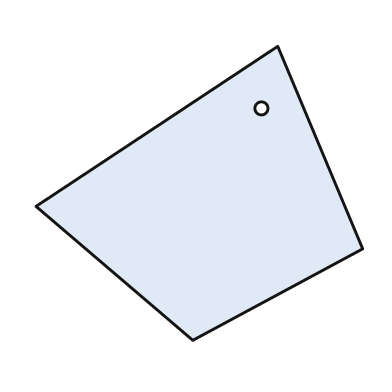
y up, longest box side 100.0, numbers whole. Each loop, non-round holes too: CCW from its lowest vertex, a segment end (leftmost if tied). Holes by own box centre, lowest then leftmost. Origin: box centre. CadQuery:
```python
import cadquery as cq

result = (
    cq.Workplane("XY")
    .moveTo(-2.0, -45.0)
    .lineTo(50.0, -17.0)
    .lineTo(24.0, 45.0)
    .lineTo(-50.0, -4.0)
    .close()
    .moveTo(19.0, 26.0)
    .circle(2.0)
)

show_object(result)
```